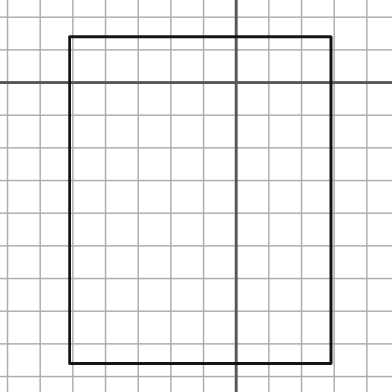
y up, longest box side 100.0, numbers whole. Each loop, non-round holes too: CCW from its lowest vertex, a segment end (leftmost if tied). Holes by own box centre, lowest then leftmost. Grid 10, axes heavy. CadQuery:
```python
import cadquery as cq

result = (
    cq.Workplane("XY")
    .moveTo(-51.0, -86.0)
    .lineTo(29.0, -86.0)
    .lineTo(29.0, 14.0)
    .lineTo(-51.0, 14.0)
    .close()
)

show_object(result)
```